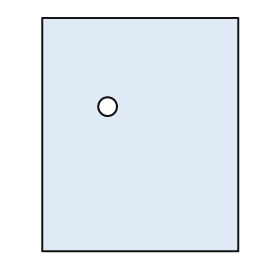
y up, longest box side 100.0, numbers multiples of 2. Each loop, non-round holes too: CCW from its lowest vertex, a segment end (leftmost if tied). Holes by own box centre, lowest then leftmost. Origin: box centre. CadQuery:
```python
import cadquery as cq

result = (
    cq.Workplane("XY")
    .moveTo(-42.0, -50.0)
    .lineTo(42.0, -50.0)
    .lineTo(42.0, 50.0)
    .lineTo(-42.0, 50.0)
    .close()
    .moveTo(-14.0, 12.0)
    .circle(4.0)
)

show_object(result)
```